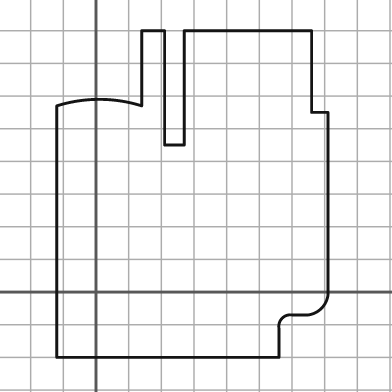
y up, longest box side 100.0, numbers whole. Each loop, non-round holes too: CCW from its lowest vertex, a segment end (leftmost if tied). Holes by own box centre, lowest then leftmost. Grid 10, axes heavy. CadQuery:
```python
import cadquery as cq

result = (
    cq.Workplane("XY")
    .moveTo(-12.0, -20.0)
    .lineTo(56.0, -20.0)
    .lineTo(56.0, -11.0)
    .threePointArc((57.0, -8.0), (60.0, -7.0))
    .lineTo(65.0, -7.0)
    .threePointArc((69.0, -5.0), (71.0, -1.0))
    .lineTo(71.0, 55.0)
    .lineTo(66.0, 55.0)
    .lineTo(66.0, 80.0)
    .lineTo(27.0, 80.0)
    .lineTo(27.0, 45.0)
    .lineTo(21.0, 45.0)
    .lineTo(21.0, 80.0)
    .lineTo(14.0, 80.0)
    .lineTo(14.0, 57.0)
    .threePointArc((1.0, 59.0), (-12.0, 57.0))
    .close()
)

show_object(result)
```